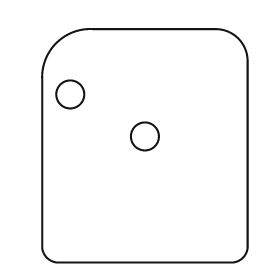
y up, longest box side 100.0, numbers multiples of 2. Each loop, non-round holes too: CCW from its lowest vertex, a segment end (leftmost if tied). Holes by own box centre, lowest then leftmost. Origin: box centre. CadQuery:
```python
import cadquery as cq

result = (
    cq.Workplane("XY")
    .moveTo(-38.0, -50.0)
    .lineTo(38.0, -50.0)
    .threePointArc((42.0, -48.0), (44.0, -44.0))
    .lineTo(44.0, 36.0)
    .threePointArc((40.0, 46.0), (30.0, 50.0))
    .lineTo(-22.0, 50.0)
    .threePointArc((-38.0, 44.0), (-44.0, 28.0))
    .lineTo(-44.0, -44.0)
    .threePointArc((-42.0, -48.0), (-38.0, -50.0))
    .close()
    .moveTo(0.0, 4.0)
    .circle(6.0)
    .moveTo(-32.0, 22.0)
    .circle(6.0)
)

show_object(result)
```